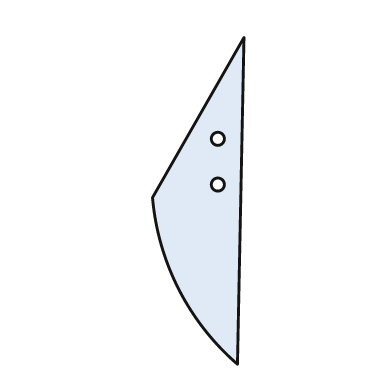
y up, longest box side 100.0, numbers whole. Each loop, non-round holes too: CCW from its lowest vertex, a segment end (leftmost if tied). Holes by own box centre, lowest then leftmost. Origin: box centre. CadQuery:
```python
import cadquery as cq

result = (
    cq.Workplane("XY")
    .moveTo(12.0, -50.0)
    .lineTo(14.0, 50.0)
    .lineTo(-14.0, 1.0)
    .threePointArc((-6.0, -27.0), (12.0, -50.0))
    .close()
    .moveTo(6.0, 5.0)
    .circle(2.0)
    .moveTo(6.0, 19.0)
    .circle(2.0)
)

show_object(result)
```